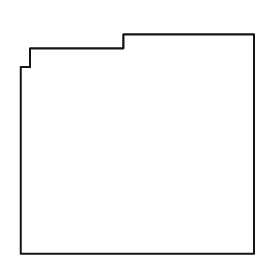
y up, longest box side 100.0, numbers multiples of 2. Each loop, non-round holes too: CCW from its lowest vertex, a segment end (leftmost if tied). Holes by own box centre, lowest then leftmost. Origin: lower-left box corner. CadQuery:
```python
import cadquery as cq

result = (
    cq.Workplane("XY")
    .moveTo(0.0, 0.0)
    .lineTo(100.0, 0.0)
    .lineTo(100.0, 94.0)
    .lineTo(44.0, 94.0)
    .lineTo(44.0, 88.0)
    .lineTo(4.0, 88.0)
    .lineTo(4.0, 80.0)
    .lineTo(0.0, 80.0)
    .close()
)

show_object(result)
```